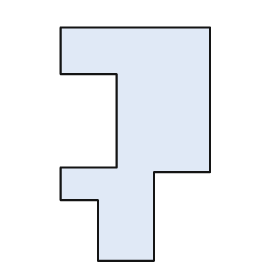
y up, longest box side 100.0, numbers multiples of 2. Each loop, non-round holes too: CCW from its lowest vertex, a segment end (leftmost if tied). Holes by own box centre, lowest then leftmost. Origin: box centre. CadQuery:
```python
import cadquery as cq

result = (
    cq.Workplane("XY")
    .moveTo(-16.0, -50.0)
    .lineTo(8.0, -50.0)
    .lineTo(8.0, -12.0)
    .lineTo(32.0, -12.0)
    .lineTo(32.0, 50.0)
    .lineTo(-32.0, 50.0)
    .lineTo(-32.0, 30.0)
    .lineTo(-8.0, 30.0)
    .lineTo(-8.0, -10.0)
    .lineTo(-32.0, -10.0)
    .lineTo(-32.0, -24.0)
    .lineTo(-16.0, -24.0)
    .close()
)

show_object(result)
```